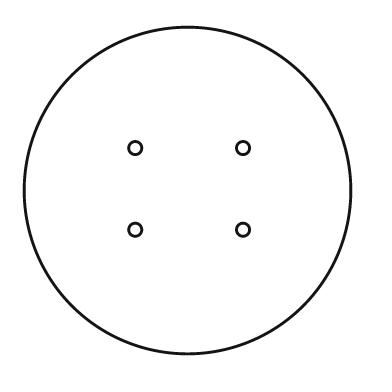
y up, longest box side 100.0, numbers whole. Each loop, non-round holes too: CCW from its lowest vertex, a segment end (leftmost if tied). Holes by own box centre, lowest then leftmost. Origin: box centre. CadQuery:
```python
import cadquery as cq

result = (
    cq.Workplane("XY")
    .moveTo(0.0, 0.0)
    .circle(50.0)
    .moveTo(-16.0, -12.0)
    .circle(2.0)
    .moveTo(17.0, -12.0)
    .circle(2.0)
    .moveTo(-16.0, 13.0)
    .circle(2.0)
    .moveTo(17.0, 13.0)
    .circle(2.0)
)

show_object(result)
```